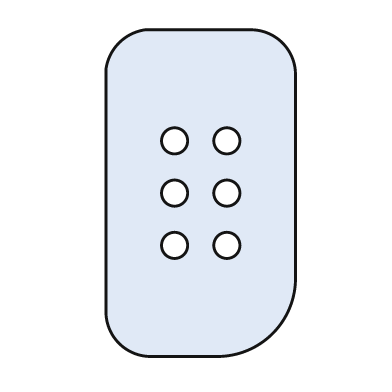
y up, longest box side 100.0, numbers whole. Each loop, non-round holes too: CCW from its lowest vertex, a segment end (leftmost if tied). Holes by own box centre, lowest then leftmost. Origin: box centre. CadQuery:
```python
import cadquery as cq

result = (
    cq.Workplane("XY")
    .moveTo(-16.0, -50.0)
    .lineTo(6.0, -50.0)
    .threePointArc((22.0, -43.0), (29.0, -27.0))
    .lineTo(29.0, 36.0)
    .threePointArc((25.0, 46.0), (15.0, 50.0))
    .lineTo(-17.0, 50.0)
    .threePointArc((-25.0, 46.0), (-29.0, 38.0))
    .lineTo(-29.0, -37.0)
    .threePointArc((-25.0, -46.0), (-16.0, -50.0))
    .close()
    .moveTo(-8.0, -16.0)
    .circle(4.0)
    .moveTo(8.0, -16.0)
    .circle(4.0)
    .moveTo(-8.0, 0.0)
    .circle(4.0)
    .moveTo(8.0, 0.0)
    .circle(4.0)
    .moveTo(-8.0, 16.0)
    .circle(4.0)
    .moveTo(8.0, 16.0)
    .circle(4.0)
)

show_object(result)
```